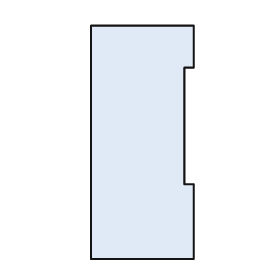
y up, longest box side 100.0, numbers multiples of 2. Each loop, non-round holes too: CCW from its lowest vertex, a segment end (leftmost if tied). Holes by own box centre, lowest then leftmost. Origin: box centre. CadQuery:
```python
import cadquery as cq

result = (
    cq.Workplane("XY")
    .moveTo(-22.0, -50.0)
    .lineTo(22.0, -50.0)
    .lineTo(22.0, -18.0)
    .lineTo(18.0, -18.0)
    .lineTo(18.0, 32.0)
    .lineTo(22.0, 32.0)
    .lineTo(22.0, 50.0)
    .lineTo(-22.0, 50.0)
    .close()
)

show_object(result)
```